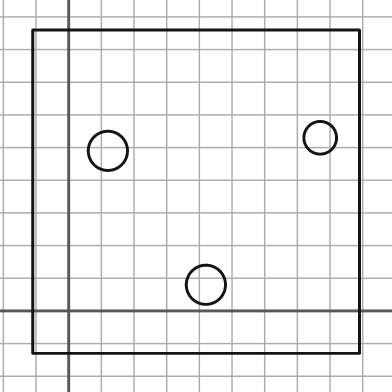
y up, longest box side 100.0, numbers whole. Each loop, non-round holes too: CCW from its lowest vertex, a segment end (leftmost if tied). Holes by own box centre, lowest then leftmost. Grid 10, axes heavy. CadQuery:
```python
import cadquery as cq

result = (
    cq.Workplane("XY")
    .moveTo(-11.0, -13.0)
    .lineTo(89.0, -13.0)
    .lineTo(89.0, 86.0)
    .lineTo(-11.0, 86.0)
    .close()
    .moveTo(42.0, 8.0)
    .circle(6.0)
    .moveTo(12.0, 49.0)
    .circle(6.0)
    .moveTo(77.0, 53.0)
    .circle(5.0)
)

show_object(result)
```